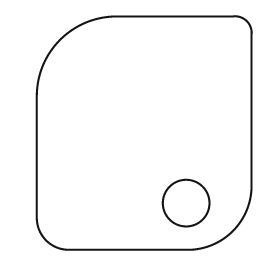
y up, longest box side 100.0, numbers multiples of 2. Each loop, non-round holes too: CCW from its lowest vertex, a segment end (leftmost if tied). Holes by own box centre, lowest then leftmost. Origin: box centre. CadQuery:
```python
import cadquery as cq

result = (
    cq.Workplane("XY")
    .moveTo(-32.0, -50.0)
    .lineTo(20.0, -50.0)
    .threePointArc((38.0, -42.0), (46.0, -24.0))
    .lineTo(46.0, 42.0)
    .threePointArc((44.0, 48.0), (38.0, 50.0))
    .lineTo(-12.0, 50.0)
    .threePointArc((-36.0, 40.0), (-46.0, 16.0))
    .lineTo(-46.0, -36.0)
    .threePointArc((-42.0, -46.0), (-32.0, -50.0))
    .close()
    .moveTo(18.0, -30.0)
    .circle(10.0)
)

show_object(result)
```